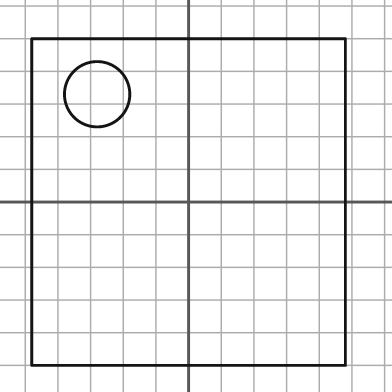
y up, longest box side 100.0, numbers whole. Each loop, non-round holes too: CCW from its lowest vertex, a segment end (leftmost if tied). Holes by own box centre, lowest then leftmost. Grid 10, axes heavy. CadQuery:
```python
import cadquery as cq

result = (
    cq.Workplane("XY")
    .moveTo(-48.0, -50.0)
    .lineTo(48.0, -50.0)
    .lineTo(48.0, 50.0)
    .lineTo(-48.0, 50.0)
    .close()
    .moveTo(-28.0, 33.0)
    .circle(10.0)
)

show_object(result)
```